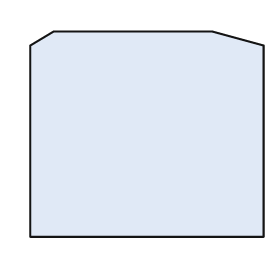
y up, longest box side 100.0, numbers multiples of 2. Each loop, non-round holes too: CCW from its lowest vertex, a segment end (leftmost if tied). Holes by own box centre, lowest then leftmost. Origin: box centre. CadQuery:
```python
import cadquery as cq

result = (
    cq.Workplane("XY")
    .moveTo(-50.0, -44.0)
    .lineTo(50.0, -44.0)
    .lineTo(50.0, 38.0)
    .lineTo(28.0, 44.0)
    .lineTo(-40.0, 44.0)
    .lineTo(-50.0, 38.0)
    .close()
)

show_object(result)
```